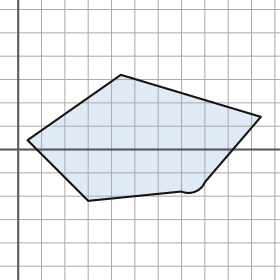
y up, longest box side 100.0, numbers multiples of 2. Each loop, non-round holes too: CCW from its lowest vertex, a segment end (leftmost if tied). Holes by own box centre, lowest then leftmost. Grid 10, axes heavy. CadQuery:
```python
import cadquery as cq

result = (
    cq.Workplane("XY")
    .moveTo(30.0, -22.0)
    .lineTo(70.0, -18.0)
    .threePointArc((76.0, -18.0), (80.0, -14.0))
    .lineTo(104.0, 14.0)
    .lineTo(44.0, 32.0)
    .lineTo(4.0, 4.0)
    .close()
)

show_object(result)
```